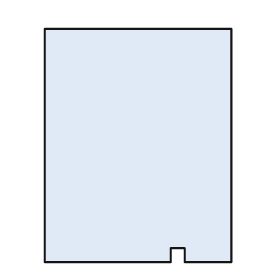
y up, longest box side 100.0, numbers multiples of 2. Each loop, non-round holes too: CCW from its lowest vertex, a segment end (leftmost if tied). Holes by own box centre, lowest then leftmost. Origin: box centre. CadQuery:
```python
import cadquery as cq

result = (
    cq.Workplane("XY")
    .moveTo(-40.0, -50.0)
    .lineTo(14.0, -50.0)
    .lineTo(14.0, -44.0)
    .lineTo(20.0, -44.0)
    .lineTo(20.0, -50.0)
    .lineTo(40.0, -50.0)
    .lineTo(40.0, 50.0)
    .lineTo(-40.0, 50.0)
    .close()
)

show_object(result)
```